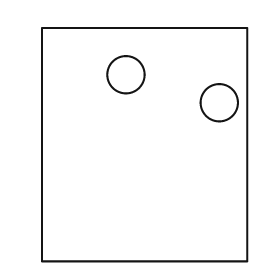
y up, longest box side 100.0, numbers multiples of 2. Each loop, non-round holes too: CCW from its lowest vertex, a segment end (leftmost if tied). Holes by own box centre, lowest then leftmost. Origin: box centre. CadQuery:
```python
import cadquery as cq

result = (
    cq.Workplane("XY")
    .moveTo(-44.0, -50.0)
    .lineTo(44.0, -50.0)
    .lineTo(44.0, 50.0)
    .lineTo(-44.0, 50.0)
    .close()
    .moveTo(32.0, 18.0)
    .circle(8.0)
    .moveTo(-8.0, 30.0)
    .circle(8.0)
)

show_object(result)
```